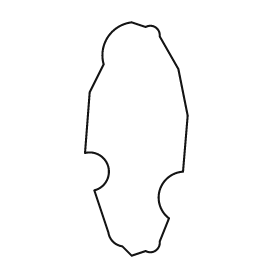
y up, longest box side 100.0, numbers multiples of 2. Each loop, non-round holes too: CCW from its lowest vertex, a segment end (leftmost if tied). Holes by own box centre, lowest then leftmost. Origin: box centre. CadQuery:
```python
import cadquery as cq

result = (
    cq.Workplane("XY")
    .moveTo(-2.0, -50.0)
    .lineTo(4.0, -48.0)
    .threePointArc((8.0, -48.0), (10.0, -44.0))
    .lineTo(14.0, -34.0)
    .threePointArc((10.0, -22.0), (20.0, -14.0))
    .lineTo(22.0, 10.0)
    .lineTo(18.0, 30.0)
    .lineTo(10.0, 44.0)
    .threePointArc((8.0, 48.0), (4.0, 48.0))
    .lineTo(-2.0, 50.0)
    .threePointArc((-12.0, 44.0), (-14.0, 32.0))
    .lineTo(-20.0, 20.0)
    .lineTo(-22.0, -6.0)
    .threePointArc((-12.0, -12.0), (-18.0, -22.0))
    .lineTo(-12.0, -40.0)
    .threePointArc((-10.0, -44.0), (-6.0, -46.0))
    .close()
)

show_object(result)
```